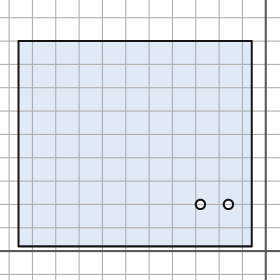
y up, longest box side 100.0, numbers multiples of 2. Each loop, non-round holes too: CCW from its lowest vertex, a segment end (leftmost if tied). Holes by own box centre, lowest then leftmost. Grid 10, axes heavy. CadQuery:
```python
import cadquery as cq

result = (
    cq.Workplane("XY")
    .moveTo(-106.0, 2.0)
    .lineTo(-6.0, 2.0)
    .lineTo(-6.0, 90.0)
    .lineTo(-106.0, 90.0)
    .close()
    .moveTo(-28.0, 20.0)
    .circle(2.0)
    .moveTo(-16.0, 20.0)
    .circle(2.0)
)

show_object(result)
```